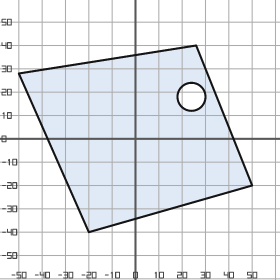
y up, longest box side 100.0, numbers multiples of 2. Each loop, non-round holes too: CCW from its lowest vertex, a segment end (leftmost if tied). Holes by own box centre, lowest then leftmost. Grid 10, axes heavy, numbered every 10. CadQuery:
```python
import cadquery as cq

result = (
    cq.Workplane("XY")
    .moveTo(-20.0, -40.0)
    .lineTo(50.0, -20.0)
    .lineTo(26.0, 40.0)
    .lineTo(-50.0, 28.0)
    .close()
    .moveTo(24.0, 18.0)
    .circle(6.0)
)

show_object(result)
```